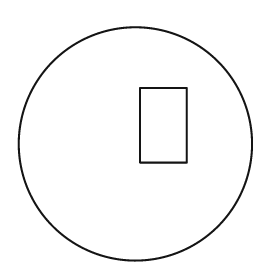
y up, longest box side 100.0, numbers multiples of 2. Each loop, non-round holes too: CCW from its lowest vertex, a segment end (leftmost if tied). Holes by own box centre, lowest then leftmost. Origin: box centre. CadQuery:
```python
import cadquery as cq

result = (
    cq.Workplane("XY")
    .moveTo(0.0, 0.0)
    .circle(50.0)
    .moveTo(2.0, -8.0)
    .lineTo(22.0, -8.0)
    .lineTo(22.0, 24.0)
    .lineTo(2.0, 24.0)
    .close()
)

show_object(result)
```